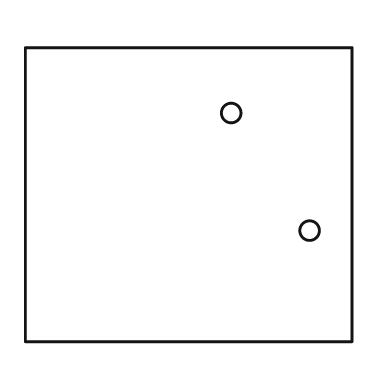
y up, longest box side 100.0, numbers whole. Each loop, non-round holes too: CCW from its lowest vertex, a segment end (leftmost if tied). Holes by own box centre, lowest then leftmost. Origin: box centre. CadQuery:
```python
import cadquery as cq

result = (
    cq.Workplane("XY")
    .moveTo(-50.0, -45.0)
    .lineTo(50.0, -45.0)
    .lineTo(50.0, 45.0)
    .lineTo(-50.0, 45.0)
    .close()
    .moveTo(37.0, -11.0)
    .circle(3.0)
    .moveTo(13.0, 25.0)
    .circle(3.0)
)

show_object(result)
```